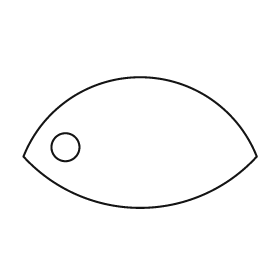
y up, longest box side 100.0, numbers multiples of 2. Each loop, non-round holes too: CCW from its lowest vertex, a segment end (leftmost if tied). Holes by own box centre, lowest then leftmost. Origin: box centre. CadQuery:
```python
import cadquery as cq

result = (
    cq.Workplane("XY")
    .moveTo(-50.0, -6.0)
    .threePointArc((0.0, -28.0), (50.0, -6.0))
    .threePointArc((0.0, 28.0), (-50.0, -6.0))
    .close()
    .moveTo(-32.0, -2.0)
    .circle(6.0)
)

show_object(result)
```